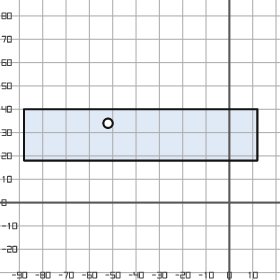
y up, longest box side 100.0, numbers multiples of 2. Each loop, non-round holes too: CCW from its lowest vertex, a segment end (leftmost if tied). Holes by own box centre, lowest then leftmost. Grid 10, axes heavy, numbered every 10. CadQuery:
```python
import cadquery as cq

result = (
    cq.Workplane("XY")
    .moveTo(-88.0, 18.0)
    .lineTo(12.0, 18.0)
    .lineTo(12.0, 40.0)
    .lineTo(-88.0, 40.0)
    .close()
    .moveTo(-52.0, 34.0)
    .circle(2.0)
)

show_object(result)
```